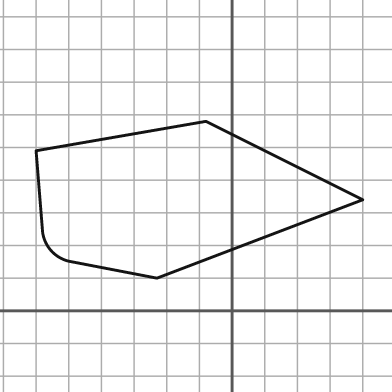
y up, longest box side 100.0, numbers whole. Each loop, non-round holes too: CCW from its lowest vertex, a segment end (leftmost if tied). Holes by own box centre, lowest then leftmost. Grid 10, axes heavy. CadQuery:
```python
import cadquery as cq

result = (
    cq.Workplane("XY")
    .moveTo(-23.0, 10.0)
    .lineTo(40.0, 34.0)
    .lineTo(-8.0, 58.0)
    .lineTo(-60.0, 49.0)
    .lineTo(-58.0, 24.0)
    .threePointArc((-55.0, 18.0), (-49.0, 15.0))
    .close()
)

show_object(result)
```